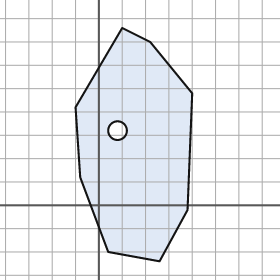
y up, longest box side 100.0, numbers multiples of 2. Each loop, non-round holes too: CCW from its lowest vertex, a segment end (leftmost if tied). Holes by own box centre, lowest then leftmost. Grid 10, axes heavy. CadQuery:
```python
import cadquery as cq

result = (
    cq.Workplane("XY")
    .moveTo(26.0, -24.0)
    .lineTo(38.0, -2.0)
    .lineTo(40.0, 48.0)
    .lineTo(22.0, 70.0)
    .lineTo(10.0, 76.0)
    .lineTo(-10.0, 42.0)
    .lineTo(-8.0, 12.0)
    .lineTo(4.0, -20.0)
    .close()
    .moveTo(8.0, 32.0)
    .circle(4.0)
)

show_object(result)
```